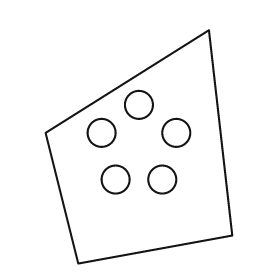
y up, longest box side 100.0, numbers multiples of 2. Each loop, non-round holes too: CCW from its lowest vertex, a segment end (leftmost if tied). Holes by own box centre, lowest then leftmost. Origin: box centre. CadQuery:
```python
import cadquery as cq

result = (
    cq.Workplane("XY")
    .moveTo(-26.0, -50.0)
    .lineTo(40.0, -38.0)
    .lineTo(30.0, 50.0)
    .lineTo(-40.0, 6.0)
    .close()
    .moveTo(-10.0, -14.0)
    .circle(6.0)
    .moveTo(10.0, -14.0)
    .circle(6.0)
    .moveTo(-16.0, 6.0)
    .circle(6.0)
    .moveTo(16.0, 6.0)
    .circle(6.0)
    .moveTo(0.0, 18.0)
    .circle(6.0)
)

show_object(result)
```